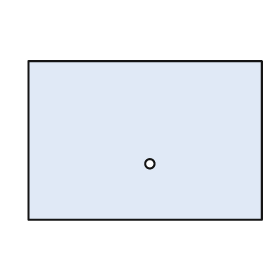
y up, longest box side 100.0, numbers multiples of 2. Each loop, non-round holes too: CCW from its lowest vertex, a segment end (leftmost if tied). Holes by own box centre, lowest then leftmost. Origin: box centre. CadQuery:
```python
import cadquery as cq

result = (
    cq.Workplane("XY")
    .moveTo(-50.0, -34.0)
    .lineTo(50.0, -34.0)
    .lineTo(50.0, 34.0)
    .lineTo(-50.0, 34.0)
    .close()
    .moveTo(2.0, -10.0)
    .circle(2.0)
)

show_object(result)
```